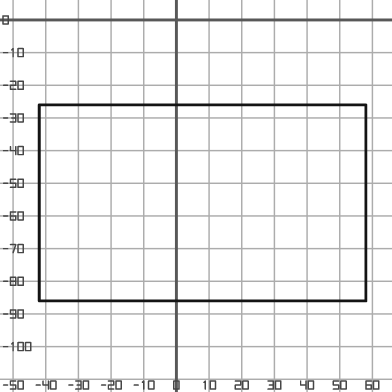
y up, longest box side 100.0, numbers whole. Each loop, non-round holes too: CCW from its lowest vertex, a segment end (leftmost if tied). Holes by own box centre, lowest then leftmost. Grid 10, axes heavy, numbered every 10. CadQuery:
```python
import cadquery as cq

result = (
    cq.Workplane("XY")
    .moveTo(-42.0, -86.0)
    .lineTo(58.0, -86.0)
    .lineTo(58.0, -26.0)
    .lineTo(-42.0, -26.0)
    .close()
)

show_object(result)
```